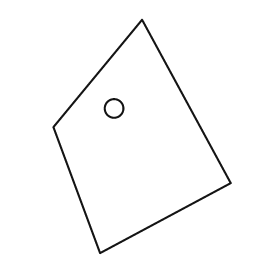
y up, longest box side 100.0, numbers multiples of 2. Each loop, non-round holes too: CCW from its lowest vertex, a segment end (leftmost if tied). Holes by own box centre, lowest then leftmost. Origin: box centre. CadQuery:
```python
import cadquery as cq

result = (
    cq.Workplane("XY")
    .moveTo(-18.0, -50.0)
    .lineTo(38.0, -20.0)
    .lineTo(0.0, 50.0)
    .lineTo(-38.0, 4.0)
    .close()
    .moveTo(-12.0, 12.0)
    .circle(4.0)
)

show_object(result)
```